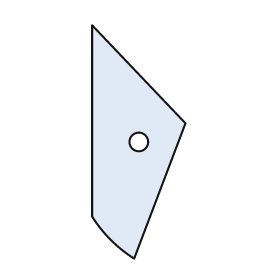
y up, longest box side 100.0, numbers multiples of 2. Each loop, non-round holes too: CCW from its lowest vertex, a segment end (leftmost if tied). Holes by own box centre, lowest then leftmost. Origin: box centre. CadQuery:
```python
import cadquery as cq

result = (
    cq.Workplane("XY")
    .moveTo(-2.0, -50.0)
    .lineTo(20.0, 8.0)
    .lineTo(-20.0, 50.0)
    .lineTo(-20.0, -32.0)
    .threePointArc((-12.0, -42.0), (-2.0, -50.0))
    .close()
    .moveTo(0.0, 0.0)
    .circle(4.0)
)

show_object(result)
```